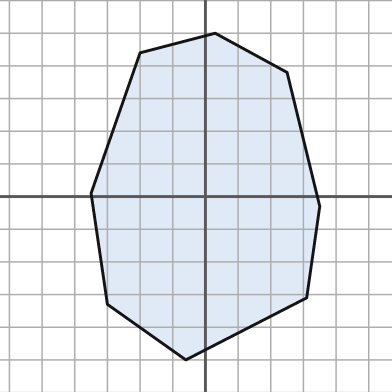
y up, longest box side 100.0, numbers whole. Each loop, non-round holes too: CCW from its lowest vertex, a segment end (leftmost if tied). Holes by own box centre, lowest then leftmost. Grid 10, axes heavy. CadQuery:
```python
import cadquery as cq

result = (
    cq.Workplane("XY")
    .moveTo(-6.0, -50.0)
    .lineTo(31.0, -31.0)
    .lineTo(35.0, -3.0)
    .lineTo(25.0, 38.0)
    .lineTo(3.0, 50.0)
    .lineTo(-20.0, 44.0)
    .lineTo(-35.0, 1.0)
    .lineTo(-30.0, -33.0)
    .close()
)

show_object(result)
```